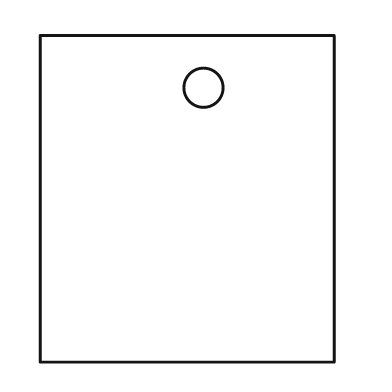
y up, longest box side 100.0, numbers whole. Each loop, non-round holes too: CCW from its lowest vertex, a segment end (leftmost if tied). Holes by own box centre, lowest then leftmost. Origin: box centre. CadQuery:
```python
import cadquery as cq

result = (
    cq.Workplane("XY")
    .moveTo(-45.0, -50.0)
    .lineTo(45.0, -50.0)
    .lineTo(45.0, 50.0)
    .lineTo(-45.0, 50.0)
    .close()
    .moveTo(5.0, 34.0)
    .circle(6.0)
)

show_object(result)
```